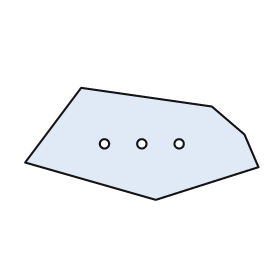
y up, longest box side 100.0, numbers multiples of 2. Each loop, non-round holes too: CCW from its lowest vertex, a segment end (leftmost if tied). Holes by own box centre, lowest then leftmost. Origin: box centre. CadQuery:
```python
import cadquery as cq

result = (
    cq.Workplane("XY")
    .moveTo(6.0, -24.0)
    .lineTo(50.0, -10.0)
    .lineTo(44.0, 4.0)
    .lineTo(30.0, 16.0)
    .lineTo(-26.0, 24.0)
    .lineTo(-50.0, -8.0)
    .close()
    .moveTo(-16.0, 0.0)
    .circle(2.0)
    .moveTo(0.0, 0.0)
    .circle(2.0)
    .moveTo(16.0, 0.0)
    .circle(2.0)
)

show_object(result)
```